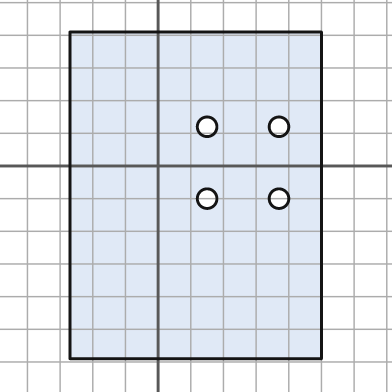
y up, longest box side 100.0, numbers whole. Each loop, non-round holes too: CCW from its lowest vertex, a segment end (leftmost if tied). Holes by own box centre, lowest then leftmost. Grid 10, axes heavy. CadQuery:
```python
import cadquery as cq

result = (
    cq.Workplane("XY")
    .moveTo(-27.0, -59.0)
    .lineTo(50.0, -59.0)
    .lineTo(50.0, 41.0)
    .lineTo(-27.0, 41.0)
    .close()
    .moveTo(15.0, -10.0)
    .circle(3.0)
    .moveTo(37.0, -10.0)
    .circle(3.0)
    .moveTo(15.0, 12.0)
    .circle(3.0)
    .moveTo(37.0, 12.0)
    .circle(3.0)
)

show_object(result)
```